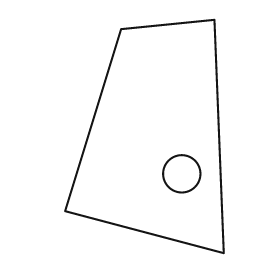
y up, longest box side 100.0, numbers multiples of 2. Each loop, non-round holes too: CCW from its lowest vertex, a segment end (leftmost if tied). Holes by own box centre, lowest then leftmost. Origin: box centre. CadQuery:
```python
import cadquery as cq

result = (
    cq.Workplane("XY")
    .moveTo(34.0, -50.0)
    .lineTo(30.0, 50.0)
    .lineTo(-10.0, 46.0)
    .lineTo(-34.0, -32.0)
    .close()
    .moveTo(16.0, -16.0)
    .circle(8.0)
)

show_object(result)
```